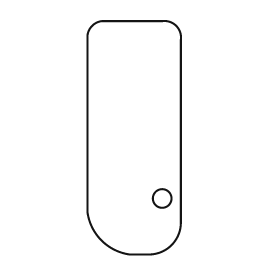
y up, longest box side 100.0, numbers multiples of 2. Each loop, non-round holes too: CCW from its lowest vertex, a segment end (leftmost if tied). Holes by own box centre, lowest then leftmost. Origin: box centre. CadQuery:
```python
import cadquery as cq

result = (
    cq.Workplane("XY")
    .moveTo(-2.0, -50.0)
    .lineTo(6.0, -50.0)
    .threePointArc((16.0, -46.0), (20.0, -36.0))
    .lineTo(20.0, 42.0)
    .threePointArc((18.0, 48.0), (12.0, 50.0))
    .lineTo(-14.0, 50.0)
    .threePointArc((-18.0, 48.0), (-20.0, 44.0))
    .lineTo(-20.0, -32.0)
    .threePointArc((-14.0, -44.0), (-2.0, -50.0))
    .close()
    .moveTo(12.0, -26.0)
    .circle(4.0)
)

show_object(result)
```